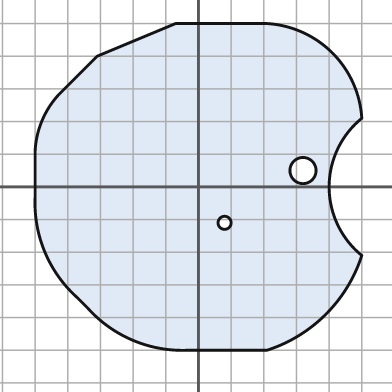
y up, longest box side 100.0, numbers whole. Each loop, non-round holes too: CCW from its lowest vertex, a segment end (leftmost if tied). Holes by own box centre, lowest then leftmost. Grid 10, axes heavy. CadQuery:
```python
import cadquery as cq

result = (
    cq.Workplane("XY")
    .moveTo(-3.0, -50.0)
    .lineTo(21.0, -50.0)
    .threePointArc((39.0, -39.0), (50.0, -21.0))
    .threePointArc((40.0, 0.0), (50.0, 21.0))
    .threePointArc((41.0, 41.0), (21.0, 50.0))
    .lineTo(-7.0, 50.0)
    .lineTo(-31.0, 40.0)
    .lineTo(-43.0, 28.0)
    .threePointArc((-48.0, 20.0), (-50.0, 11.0))
    .lineTo(-50.0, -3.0)
    .threePointArc((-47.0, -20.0), (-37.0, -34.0))
    .lineTo(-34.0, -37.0)
    .threePointArc((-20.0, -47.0), (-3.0, -50.0))
    .close()
    .moveTo(8.0, -11.0)
    .circle(2.0)
    .moveTo(32.0, 5.0)
    .circle(4.0)
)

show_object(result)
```